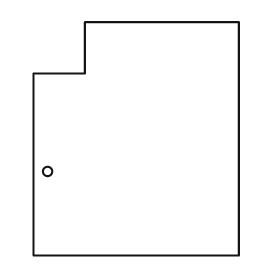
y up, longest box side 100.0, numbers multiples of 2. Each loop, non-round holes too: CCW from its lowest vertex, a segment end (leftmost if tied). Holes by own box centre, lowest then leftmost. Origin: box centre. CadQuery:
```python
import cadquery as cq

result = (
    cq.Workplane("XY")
    .moveTo(-44.0, -50.0)
    .lineTo(44.0, -50.0)
    .lineTo(44.0, 50.0)
    .lineTo(-22.0, 50.0)
    .lineTo(-22.0, 28.0)
    .lineTo(-44.0, 28.0)
    .close()
    .moveTo(-38.0, -14.0)
    .circle(2.0)
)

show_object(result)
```